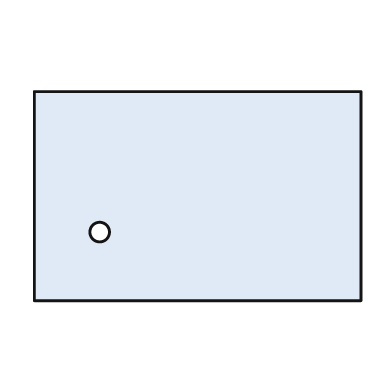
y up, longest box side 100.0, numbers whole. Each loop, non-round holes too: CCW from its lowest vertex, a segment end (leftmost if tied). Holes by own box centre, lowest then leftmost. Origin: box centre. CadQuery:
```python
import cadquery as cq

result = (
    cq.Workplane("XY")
    .moveTo(-50.0, -32.0)
    .lineTo(50.0, -32.0)
    .lineTo(50.0, 32.0)
    .lineTo(-50.0, 32.0)
    .close()
    .moveTo(-30.0, -11.0)
    .circle(3.0)
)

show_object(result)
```